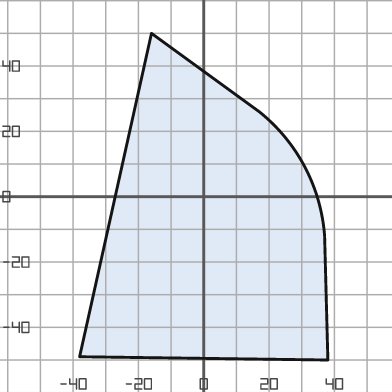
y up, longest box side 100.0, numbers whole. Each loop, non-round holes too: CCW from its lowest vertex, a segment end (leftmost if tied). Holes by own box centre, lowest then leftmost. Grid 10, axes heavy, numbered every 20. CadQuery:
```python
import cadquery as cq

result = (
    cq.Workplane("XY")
    .moveTo(38.0, -50.0)
    .lineTo(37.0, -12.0)
    .threePointArc((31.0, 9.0), (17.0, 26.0))
    .lineTo(-16.0, 50.0)
    .lineTo(-38.0, -49.0)
    .close()
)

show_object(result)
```